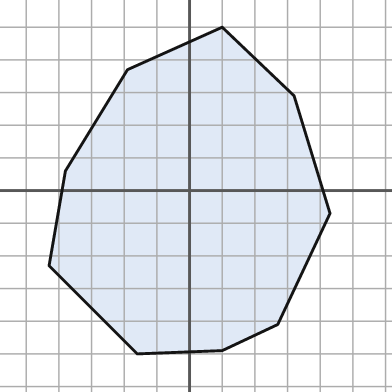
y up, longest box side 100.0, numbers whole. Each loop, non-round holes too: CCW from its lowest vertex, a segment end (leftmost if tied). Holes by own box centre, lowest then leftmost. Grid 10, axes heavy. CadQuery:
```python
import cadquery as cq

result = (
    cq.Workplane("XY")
    .moveTo(-16.0, -50.0)
    .lineTo(10.0, -49.0)
    .lineTo(27.0, -41.0)
    .lineTo(43.0, -7.0)
    .lineTo(32.0, 29.0)
    .lineTo(10.0, 50.0)
    .lineTo(-19.0, 37.0)
    .lineTo(-38.0, 6.0)
    .lineTo(-43.0, -23.0)
    .close()
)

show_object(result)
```